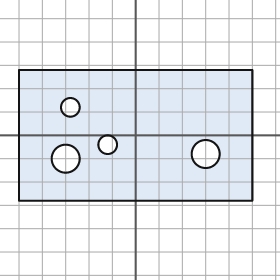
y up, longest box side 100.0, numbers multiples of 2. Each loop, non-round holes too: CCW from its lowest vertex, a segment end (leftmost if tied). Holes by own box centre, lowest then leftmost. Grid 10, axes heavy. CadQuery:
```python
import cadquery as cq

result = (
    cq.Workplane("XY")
    .moveTo(-50.0, -28.0)
    .lineTo(50.0, -28.0)
    .lineTo(50.0, 28.0)
    .lineTo(-50.0, 28.0)
    .close()
    .moveTo(-30.0, -10.0)
    .circle(6.0)
    .moveTo(30.0, -8.0)
    .circle(6.0)
    .moveTo(-12.0, -4.0)
    .circle(4.0)
    .moveTo(-28.0, 12.0)
    .circle(4.0)
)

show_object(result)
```